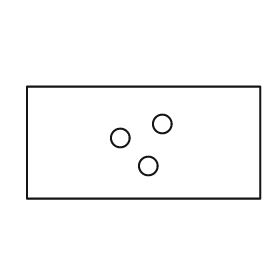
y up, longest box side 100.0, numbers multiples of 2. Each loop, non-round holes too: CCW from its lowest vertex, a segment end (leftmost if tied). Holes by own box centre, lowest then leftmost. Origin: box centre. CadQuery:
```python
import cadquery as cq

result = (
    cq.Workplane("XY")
    .moveTo(-50.0, -24.0)
    .lineTo(50.0, -24.0)
    .lineTo(50.0, 24.0)
    .lineTo(-50.0, 24.0)
    .close()
    .moveTo(2.0, -10.0)
    .circle(4.0)
    .moveTo(-10.0, 2.0)
    .circle(4.0)
    .moveTo(8.0, 8.0)
    .circle(4.0)
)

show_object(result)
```